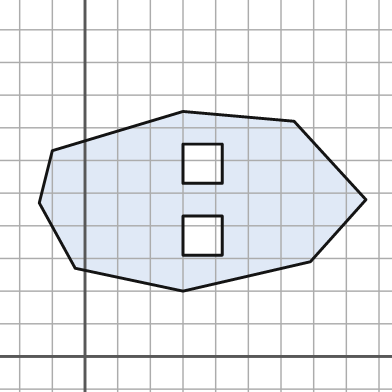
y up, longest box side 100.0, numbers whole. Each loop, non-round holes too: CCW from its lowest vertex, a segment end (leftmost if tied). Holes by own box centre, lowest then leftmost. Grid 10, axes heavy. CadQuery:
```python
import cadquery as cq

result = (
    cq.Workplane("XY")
    .moveTo(30.0, 20.0)
    .lineTo(69.0, 29.0)
    .lineTo(86.0, 48.0)
    .lineTo(64.0, 72.0)
    .lineTo(30.0, 75.0)
    .lineTo(-10.0, 63.0)
    .lineTo(-14.0, 47.0)
    .lineTo(-3.0, 27.0)
    .close()
    .moveTo(30.0, 31.0)
    .lineTo(42.0, 31.0)
    .lineTo(42.0, 43.0)
    .lineTo(30.0, 43.0)
    .close()
    .moveTo(30.0, 53.0)
    .lineTo(42.0, 53.0)
    .lineTo(42.0, 65.0)
    .lineTo(30.0, 65.0)
    .close()
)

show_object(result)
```